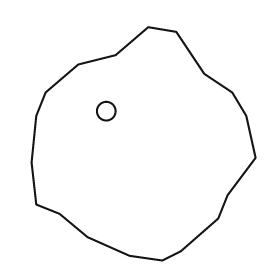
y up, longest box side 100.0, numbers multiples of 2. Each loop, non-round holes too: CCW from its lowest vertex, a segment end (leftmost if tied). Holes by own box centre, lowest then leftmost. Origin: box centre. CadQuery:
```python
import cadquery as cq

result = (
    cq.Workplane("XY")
    .moveTo(8.0, -50.0)
    .lineTo(16.0, -46.0)
    .lineTo(32.0, -32.0)
    .lineTo(36.0, -22.0)
    .lineTo(48.0, -6.0)
    .lineTo(44.0, 12.0)
    .lineTo(38.0, 22.0)
    .lineTo(26.0, 30.0)
    .lineTo(14.0, 48.0)
    .lineTo(2.0, 50.0)
    .lineTo(-12.0, 38.0)
    .lineTo(-28.0, 34.0)
    .lineTo(-42.0, 22.0)
    .lineTo(-46.0, 12.0)
    .lineTo(-48.0, -8.0)
    .lineTo(-46.0, -26.0)
    .lineTo(-36.0, -30.0)
    .lineTo(-24.0, -40.0)
    .lineTo(-6.0, -48.0)
    .close()
    .moveTo(-16.0, 14.0)
    .circle(4.0)
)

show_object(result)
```